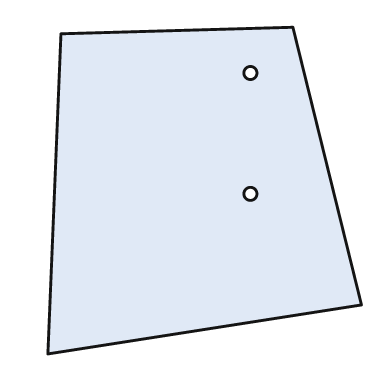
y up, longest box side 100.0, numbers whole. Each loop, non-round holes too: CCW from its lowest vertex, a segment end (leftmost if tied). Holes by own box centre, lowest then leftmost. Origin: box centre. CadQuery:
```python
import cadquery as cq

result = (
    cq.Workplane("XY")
    .moveTo(-48.0, -50.0)
    .lineTo(48.0, -35.0)
    .lineTo(27.0, 50.0)
    .lineTo(-44.0, 48.0)
    .close()
    .moveTo(14.0, -1.0)
    .circle(2.0)
    .moveTo(14.0, 36.0)
    .circle(2.0)
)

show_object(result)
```